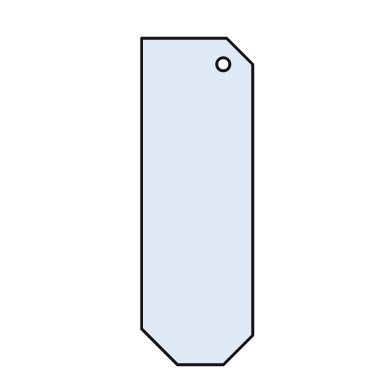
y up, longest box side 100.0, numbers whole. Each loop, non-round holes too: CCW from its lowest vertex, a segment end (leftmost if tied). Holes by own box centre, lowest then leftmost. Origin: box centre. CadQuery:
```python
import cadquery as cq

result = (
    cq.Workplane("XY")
    .moveTo(-6.0, -50.0)
    .lineTo(8.0, -50.0)
    .lineTo(17.0, -41.0)
    .lineTo(17.0, 42.0)
    .lineTo(9.0, 50.0)
    .lineTo(-17.0, 50.0)
    .lineTo(-17.0, -39.0)
    .close()
    .moveTo(8.0, 42.0)
    .circle(2.0)
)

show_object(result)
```